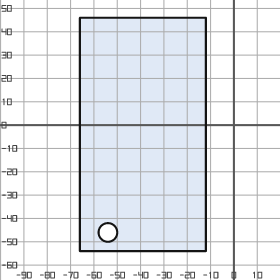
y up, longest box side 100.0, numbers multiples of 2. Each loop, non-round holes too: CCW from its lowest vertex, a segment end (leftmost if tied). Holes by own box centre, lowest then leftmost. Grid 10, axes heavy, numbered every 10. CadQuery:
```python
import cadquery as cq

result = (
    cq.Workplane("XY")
    .moveTo(-66.0, -54.0)
    .lineTo(-12.0, -54.0)
    .lineTo(-12.0, 46.0)
    .lineTo(-66.0, 46.0)
    .close()
    .moveTo(-54.0, -46.0)
    .circle(4.0)
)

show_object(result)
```